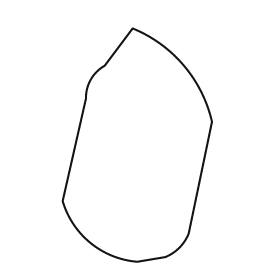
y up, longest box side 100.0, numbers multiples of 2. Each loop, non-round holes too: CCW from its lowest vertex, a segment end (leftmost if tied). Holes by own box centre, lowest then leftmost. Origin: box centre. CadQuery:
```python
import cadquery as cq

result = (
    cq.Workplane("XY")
    .moveTo(0.0, -50.0)
    .lineTo(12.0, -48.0)
    .threePointArc((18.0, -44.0), (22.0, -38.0))
    .lineTo(32.0, 10.0)
    .threePointArc((20.0, 34.0), (-2.0, 50.0))
    .lineTo(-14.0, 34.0)
    .threePointArc((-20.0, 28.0), (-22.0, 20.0))
    .lineTo(-32.0, -24.0)
    .threePointArc((-20.0, -42.0), (0.0, -50.0))
    .close()
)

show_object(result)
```